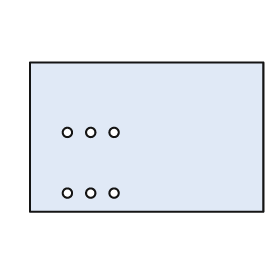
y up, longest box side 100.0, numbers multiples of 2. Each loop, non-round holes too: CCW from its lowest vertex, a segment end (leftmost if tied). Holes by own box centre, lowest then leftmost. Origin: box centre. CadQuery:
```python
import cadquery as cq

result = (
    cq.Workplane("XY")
    .moveTo(-50.0, -32.0)
    .lineTo(50.0, -32.0)
    .lineTo(50.0, 32.0)
    .lineTo(-50.0, 32.0)
    .close()
    .moveTo(-34.0, -24.0)
    .circle(2.0)
    .moveTo(-24.0, -24.0)
    .circle(2.0)
    .moveTo(-14.0, -24.0)
    .circle(2.0)
    .moveTo(-34.0, 2.0)
    .circle(2.0)
    .moveTo(-24.0, 2.0)
    .circle(2.0)
    .moveTo(-14.0, 2.0)
    .circle(2.0)
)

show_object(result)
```